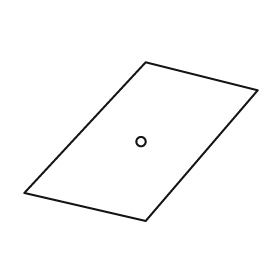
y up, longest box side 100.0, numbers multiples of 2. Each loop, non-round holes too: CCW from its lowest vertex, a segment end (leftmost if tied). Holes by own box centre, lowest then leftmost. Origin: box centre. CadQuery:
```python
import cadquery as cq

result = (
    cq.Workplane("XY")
    .moveTo(2.0, -34.0)
    .lineTo(50.0, 22.0)
    .lineTo(2.0, 34.0)
    .lineTo(-50.0, -22.0)
    .close()
    .moveTo(0.0, 0.0)
    .circle(2.0)
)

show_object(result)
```